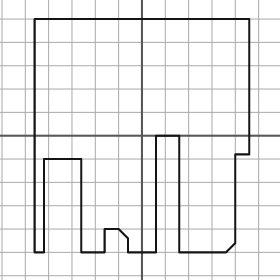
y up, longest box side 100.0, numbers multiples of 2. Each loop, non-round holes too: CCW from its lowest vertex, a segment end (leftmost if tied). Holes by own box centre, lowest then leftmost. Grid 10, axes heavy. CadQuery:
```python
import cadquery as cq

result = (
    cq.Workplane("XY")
    .moveTo(-46.0, -50.0)
    .lineTo(-42.0, -50.0)
    .lineTo(-42.0, -10.0)
    .lineTo(-26.0, -10.0)
    .lineTo(-26.0, -50.0)
    .lineTo(-16.0, -50.0)
    .lineTo(-16.0, -40.0)
    .lineTo(-10.0, -40.0)
    .lineTo(-6.0, -44.0)
    .lineTo(-6.0, -50.0)
    .lineTo(6.0, -50.0)
    .lineTo(6.0, 0.0)
    .lineTo(16.0, 0.0)
    .lineTo(16.0, -50.0)
    .lineTo(36.0, -50.0)
    .lineTo(40.0, -46.0)
    .lineTo(40.0, -8.0)
    .lineTo(46.0, -8.0)
    .lineTo(46.0, 50.0)
    .lineTo(-46.0, 50.0)
    .close()
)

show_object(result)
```